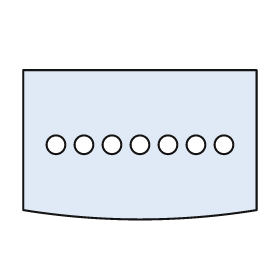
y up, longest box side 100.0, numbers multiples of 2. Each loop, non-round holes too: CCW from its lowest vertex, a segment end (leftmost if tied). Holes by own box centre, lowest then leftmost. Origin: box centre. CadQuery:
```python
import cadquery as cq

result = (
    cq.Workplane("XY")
    .moveTo(-50.0, -28.0)
    .threePointArc((0.0, -32.0), (50.0, -28.0))
    .lineTo(50.0, 32.0)
    .lineTo(-50.0, 32.0)
    .close()
    .moveTo(-36.0, 0.0)
    .circle(4.0)
    .moveTo(-24.0, 0.0)
    .circle(4.0)
    .moveTo(-12.0, 0.0)
    .circle(4.0)
    .moveTo(0.0, 0.0)
    .circle(4.0)
    .moveTo(12.0, 0.0)
    .circle(4.0)
    .moveTo(24.0, 0.0)
    .circle(4.0)
    .moveTo(36.0, 0.0)
    .circle(4.0)
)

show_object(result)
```